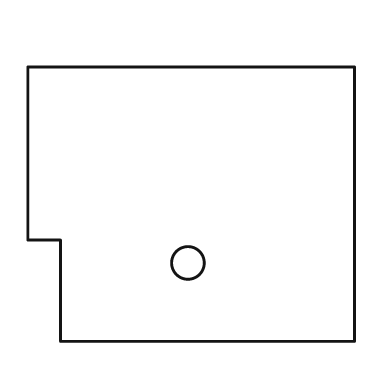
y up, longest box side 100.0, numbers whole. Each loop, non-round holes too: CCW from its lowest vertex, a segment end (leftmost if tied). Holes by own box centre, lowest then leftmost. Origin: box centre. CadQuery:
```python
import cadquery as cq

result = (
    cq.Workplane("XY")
    .moveTo(-40.0, -42.0)
    .lineTo(50.0, -42.0)
    .lineTo(50.0, 42.0)
    .lineTo(-50.0, 42.0)
    .lineTo(-50.0, -11.0)
    .lineTo(-40.0, -11.0)
    .close()
    .moveTo(-1.0, -18.0)
    .circle(5.0)
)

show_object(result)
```